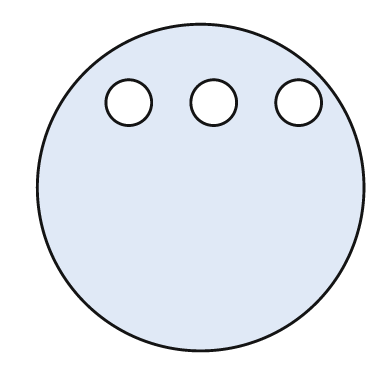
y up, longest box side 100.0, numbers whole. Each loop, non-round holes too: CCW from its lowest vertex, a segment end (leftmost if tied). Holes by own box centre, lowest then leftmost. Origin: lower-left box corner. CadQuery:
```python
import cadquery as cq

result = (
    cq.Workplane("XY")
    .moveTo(50.0, 50.0)
    .circle(50.0)
    .moveTo(28.0, 76.0)
    .circle(7.0)
    .moveTo(54.0, 76.0)
    .circle(7.0)
    .moveTo(80.0, 76.0)
    .circle(7.0)
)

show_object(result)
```